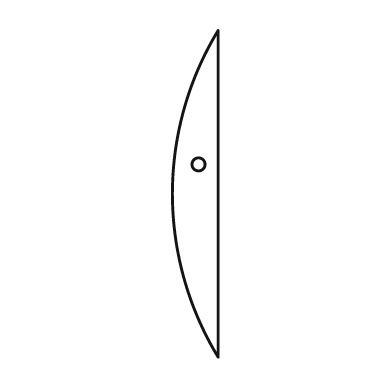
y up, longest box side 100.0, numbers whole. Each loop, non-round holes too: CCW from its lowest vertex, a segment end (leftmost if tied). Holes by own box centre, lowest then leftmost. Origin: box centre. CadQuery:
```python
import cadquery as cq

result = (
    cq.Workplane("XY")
    .moveTo(7.0, -50.0)
    .lineTo(7.0, 50.0)
    .threePointArc((-7.0, 0.0), (7.0, -50.0))
    .close()
    .moveTo(1.0, 9.0)
    .circle(2.0)
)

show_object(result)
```